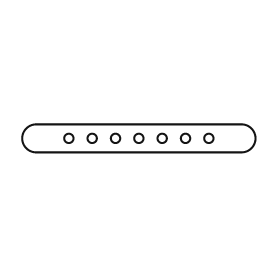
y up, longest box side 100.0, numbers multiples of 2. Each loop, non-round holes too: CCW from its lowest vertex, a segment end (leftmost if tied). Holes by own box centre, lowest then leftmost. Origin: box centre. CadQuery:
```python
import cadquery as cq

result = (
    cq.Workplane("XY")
    .moveTo(-44.0, -6.0)
    .lineTo(44.0, -6.0)
    .threePointArc((50.0, 0.0), (44.0, 6.0))
    .lineTo(-44.0, 6.0)
    .threePointArc((-50.0, 0.0), (-44.0, -6.0))
    .close()
    .moveTo(-30.0, 0.0)
    .circle(2.0)
    .moveTo(-20.0, 0.0)
    .circle(2.0)
    .moveTo(-10.0, 0.0)
    .circle(2.0)
    .moveTo(0.0, 0.0)
    .circle(2.0)
    .moveTo(10.0, 0.0)
    .circle(2.0)
    .moveTo(20.0, 0.0)
    .circle(2.0)
    .moveTo(30.0, 0.0)
    .circle(2.0)
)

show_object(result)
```